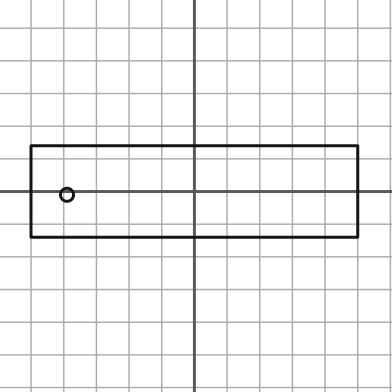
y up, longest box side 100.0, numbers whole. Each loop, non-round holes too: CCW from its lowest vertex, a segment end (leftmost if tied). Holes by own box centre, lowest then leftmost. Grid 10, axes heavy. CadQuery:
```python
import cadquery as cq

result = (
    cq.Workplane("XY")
    .moveTo(-50.0, -14.0)
    .lineTo(50.0, -14.0)
    .lineTo(50.0, 14.0)
    .lineTo(-50.0, 14.0)
    .close()
    .moveTo(-39.0, -1.0)
    .circle(2.0)
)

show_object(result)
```